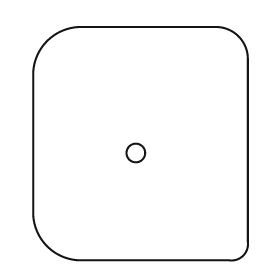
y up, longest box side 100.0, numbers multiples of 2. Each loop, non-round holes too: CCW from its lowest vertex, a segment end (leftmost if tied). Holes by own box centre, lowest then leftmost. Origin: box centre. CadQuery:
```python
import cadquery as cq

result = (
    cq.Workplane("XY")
    .moveTo(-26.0, -50.0)
    .lineTo(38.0, -50.0)
    .threePointArc((44.0, -48.0), (46.0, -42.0))
    .lineTo(46.0, 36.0)
    .threePointArc((42.0, 46.0), (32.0, 50.0))
    .lineTo(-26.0, 50.0)
    .threePointArc((-40.0, 44.0), (-46.0, 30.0))
    .lineTo(-46.0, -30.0)
    .threePointArc((-40.0, -44.0), (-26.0, -50.0))
    .close()
    .moveTo(-2.0, -4.0)
    .circle(4.0)
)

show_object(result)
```